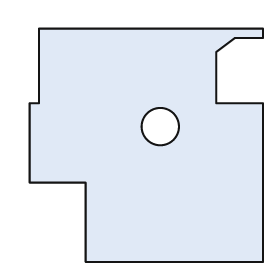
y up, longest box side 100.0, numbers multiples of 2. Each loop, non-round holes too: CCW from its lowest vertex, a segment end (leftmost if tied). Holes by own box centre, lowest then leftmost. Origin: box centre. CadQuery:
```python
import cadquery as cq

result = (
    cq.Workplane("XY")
    .moveTo(-26.0, -50.0)
    .lineTo(50.0, -50.0)
    .lineTo(50.0, 18.0)
    .lineTo(30.0, 18.0)
    .lineTo(30.0, 40.0)
    .lineTo(38.0, 46.0)
    .lineTo(50.0, 46.0)
    .lineTo(50.0, 50.0)
    .lineTo(-46.0, 50.0)
    .lineTo(-46.0, 18.0)
    .lineTo(-50.0, 18.0)
    .lineTo(-50.0, -16.0)
    .lineTo(-26.0, -16.0)
    .close()
    .moveTo(6.0, 8.0)
    .circle(8.0)
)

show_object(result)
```